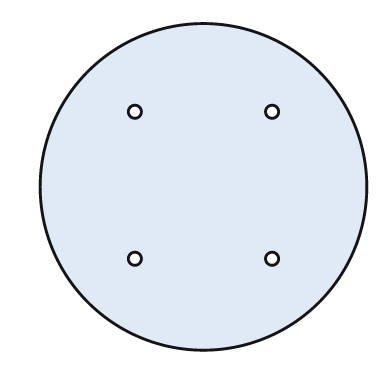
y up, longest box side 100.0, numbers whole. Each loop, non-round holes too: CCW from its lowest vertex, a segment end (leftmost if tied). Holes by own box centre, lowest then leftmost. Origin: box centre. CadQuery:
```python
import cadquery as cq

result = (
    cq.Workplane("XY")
    .moveTo(0.0, 0.0)
    .circle(50.0)
    .moveTo(-21.0, -22.0)
    .circle(2.0)
    .moveTo(21.0, -22.0)
    .circle(2.0)
    .moveTo(-21.0, 23.0)
    .circle(2.0)
    .moveTo(21.0, 23.0)
    .circle(2.0)
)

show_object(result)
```